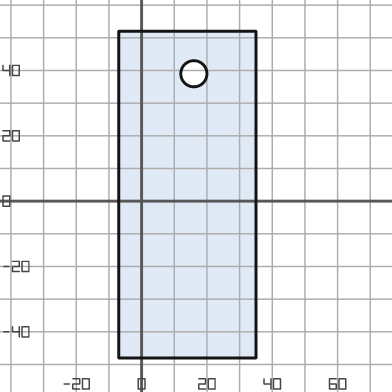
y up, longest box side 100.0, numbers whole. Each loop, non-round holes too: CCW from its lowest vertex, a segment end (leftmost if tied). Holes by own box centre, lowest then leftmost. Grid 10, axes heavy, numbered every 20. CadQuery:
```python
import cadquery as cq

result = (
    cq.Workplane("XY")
    .moveTo(-7.0, -48.0)
    .lineTo(35.0, -48.0)
    .lineTo(35.0, 52.0)
    .lineTo(-7.0, 52.0)
    .close()
    .moveTo(16.0, 39.0)
    .circle(4.0)
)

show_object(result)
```